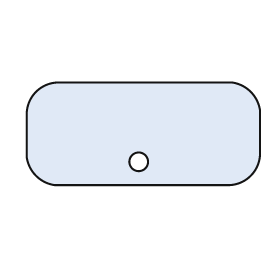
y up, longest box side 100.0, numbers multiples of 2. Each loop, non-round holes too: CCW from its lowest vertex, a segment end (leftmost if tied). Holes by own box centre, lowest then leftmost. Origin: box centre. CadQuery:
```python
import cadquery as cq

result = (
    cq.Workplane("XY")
    .moveTo(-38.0, -22.0)
    .lineTo(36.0, -22.0)
    .threePointArc((46.0, -18.0), (50.0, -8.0))
    .lineTo(50.0, 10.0)
    .threePointArc((46.0, 18.0), (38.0, 22.0))
    .lineTo(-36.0, 22.0)
    .threePointArc((-46.0, 18.0), (-50.0, 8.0))
    .lineTo(-50.0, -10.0)
    .threePointArc((-46.0, -18.0), (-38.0, -22.0))
    .close()
    .moveTo(-2.0, -12.0)
    .circle(4.0)
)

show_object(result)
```